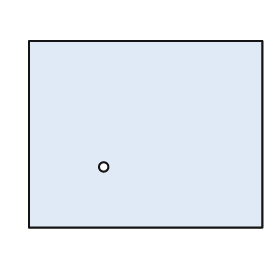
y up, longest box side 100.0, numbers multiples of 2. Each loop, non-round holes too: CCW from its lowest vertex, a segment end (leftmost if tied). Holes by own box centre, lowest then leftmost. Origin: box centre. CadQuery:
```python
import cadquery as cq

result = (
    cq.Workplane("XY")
    .moveTo(-50.0, -40.0)
    .lineTo(50.0, -40.0)
    .lineTo(50.0, 40.0)
    .lineTo(-50.0, 40.0)
    .close()
    .moveTo(-18.0, -14.0)
    .circle(2.0)
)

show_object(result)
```